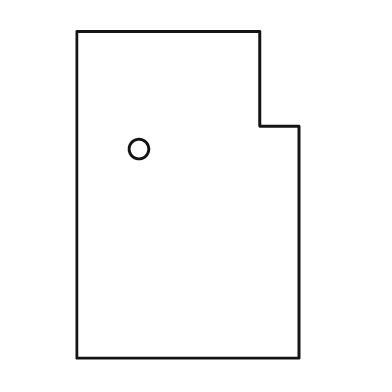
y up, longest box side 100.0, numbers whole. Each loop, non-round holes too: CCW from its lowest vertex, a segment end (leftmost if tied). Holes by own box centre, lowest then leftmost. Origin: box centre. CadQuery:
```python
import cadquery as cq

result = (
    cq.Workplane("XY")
    .moveTo(-34.0, -50.0)
    .lineTo(34.0, -50.0)
    .lineTo(34.0, 21.0)
    .lineTo(22.0, 21.0)
    .lineTo(22.0, 50.0)
    .lineTo(-34.0, 50.0)
    .close()
    .moveTo(-15.0, 14.0)
    .circle(3.0)
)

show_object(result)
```